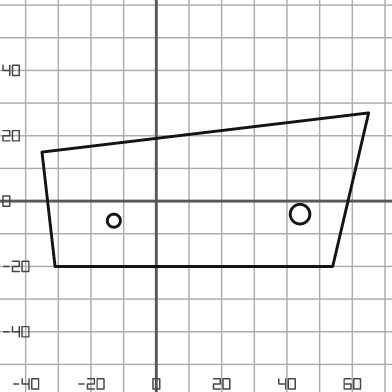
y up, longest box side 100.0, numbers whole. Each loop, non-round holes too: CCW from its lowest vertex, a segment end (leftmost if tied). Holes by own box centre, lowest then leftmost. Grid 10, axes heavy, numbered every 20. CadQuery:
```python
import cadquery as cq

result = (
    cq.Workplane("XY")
    .moveTo(-31.0, -20.0)
    .lineTo(54.0, -20.0)
    .lineTo(65.0, 27.0)
    .lineTo(-35.0, 15.0)
    .close()
    .moveTo(-13.0, -6.0)
    .circle(2.0)
    .moveTo(44.0, -4.0)
    .circle(3.0)
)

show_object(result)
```